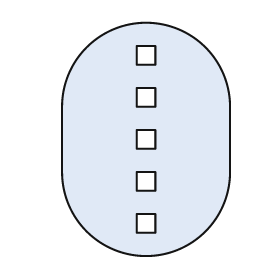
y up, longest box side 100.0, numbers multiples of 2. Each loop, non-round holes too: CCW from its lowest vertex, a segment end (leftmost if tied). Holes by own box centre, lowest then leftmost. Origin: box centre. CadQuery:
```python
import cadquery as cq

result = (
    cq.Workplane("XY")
    .moveTo(-36.0, -14.0)
    .threePointArc((0.0, -50.0), (36.0, -14.0))
    .lineTo(36.0, 14.0)
    .threePointArc((0.0, 50.0), (-36.0, 14.0))
    .close()
    .moveTo(-4.0, -40.0)
    .lineTo(4.0, -40.0)
    .lineTo(4.0, -32.0)
    .lineTo(-4.0, -32.0)
    .close()
    .moveTo(-4.0, -22.0)
    .lineTo(4.0, -22.0)
    .lineTo(4.0, -14.0)
    .lineTo(-4.0, -14.0)
    .close()
    .moveTo(-4.0, -4.0)
    .lineTo(4.0, -4.0)
    .lineTo(4.0, 4.0)
    .lineTo(-4.0, 4.0)
    .close()
    .moveTo(-4.0, 14.0)
    .lineTo(4.0, 14.0)
    .lineTo(4.0, 22.0)
    .lineTo(-4.0, 22.0)
    .close()
    .moveTo(-4.0, 32.0)
    .lineTo(4.0, 32.0)
    .lineTo(4.0, 40.0)
    .lineTo(-4.0, 40.0)
    .close()
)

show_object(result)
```